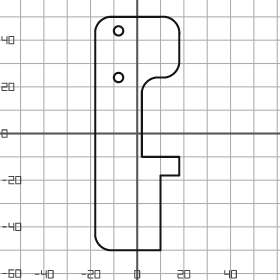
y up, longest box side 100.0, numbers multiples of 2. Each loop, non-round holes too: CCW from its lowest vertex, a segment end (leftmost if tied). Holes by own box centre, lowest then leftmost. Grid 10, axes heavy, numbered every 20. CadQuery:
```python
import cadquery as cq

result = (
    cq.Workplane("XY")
    .moveTo(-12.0, -50.0)
    .lineTo(10.0, -50.0)
    .lineTo(10.0, -18.0)
    .lineTo(18.0, -18.0)
    .lineTo(18.0, -10.0)
    .lineTo(2.0, -10.0)
    .lineTo(2.0, 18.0)
    .threePointArc((4.0, 22.0), (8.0, 24.0))
    .lineTo(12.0, 24.0)
    .threePointArc((16.0, 26.0), (18.0, 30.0))
    .lineTo(18.0, 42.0)
    .threePointArc((16.0, 48.0), (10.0, 50.0))
    .lineTo(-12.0, 50.0)
    .threePointArc((-16.0, 48.0), (-18.0, 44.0))
    .lineTo(-18.0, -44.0)
    .threePointArc((-16.0, -48.0), (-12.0, -50.0))
    .close()
    .moveTo(-8.0, 24.0)
    .circle(2.0)
    .moveTo(-8.0, 44.0)
    .circle(2.0)
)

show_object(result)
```